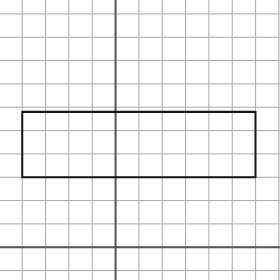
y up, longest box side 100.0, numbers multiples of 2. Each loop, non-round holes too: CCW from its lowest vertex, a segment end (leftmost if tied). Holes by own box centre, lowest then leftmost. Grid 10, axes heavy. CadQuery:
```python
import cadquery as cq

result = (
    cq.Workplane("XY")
    .moveTo(-40.0, 30.0)
    .lineTo(60.0, 30.0)
    .lineTo(60.0, 58.0)
    .lineTo(-40.0, 58.0)
    .close()
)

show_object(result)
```